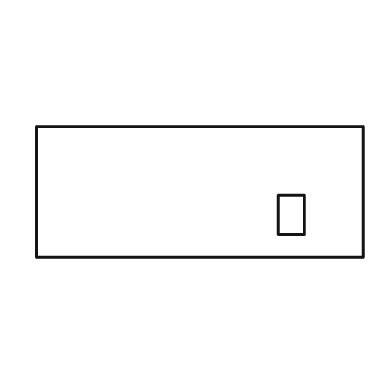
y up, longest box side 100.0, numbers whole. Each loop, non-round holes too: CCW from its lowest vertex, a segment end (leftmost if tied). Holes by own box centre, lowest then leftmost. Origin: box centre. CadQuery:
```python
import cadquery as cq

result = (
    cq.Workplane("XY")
    .moveTo(-50.0, -20.0)
    .lineTo(50.0, -20.0)
    .lineTo(50.0, 20.0)
    .lineTo(-50.0, 20.0)
    .close()
    .moveTo(24.0, -13.0)
    .lineTo(32.0, -13.0)
    .lineTo(32.0, -1.0)
    .lineTo(24.0, -1.0)
    .close()
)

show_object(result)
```